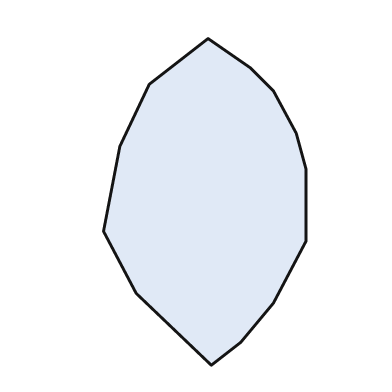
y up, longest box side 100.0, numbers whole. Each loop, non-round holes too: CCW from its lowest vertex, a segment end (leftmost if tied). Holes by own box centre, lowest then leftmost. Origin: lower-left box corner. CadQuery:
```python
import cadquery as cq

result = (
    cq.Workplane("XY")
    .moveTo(33.0, 0.0)
    .lineTo(42.0, 7.0)
    .lineTo(52.0, 19.0)
    .lineTo(62.0, 38.0)
    .lineTo(62.0, 60.0)
    .lineTo(59.0, 71.0)
    .lineTo(52.0, 84.0)
    .lineTo(45.0, 91.0)
    .lineTo(32.0, 100.0)
    .lineTo(14.0, 86.0)
    .lineTo(5.0, 67.0)
    .lineTo(0.0, 41.0)
    .lineTo(10.0, 22.0)
    .close()
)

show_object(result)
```